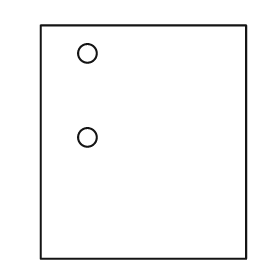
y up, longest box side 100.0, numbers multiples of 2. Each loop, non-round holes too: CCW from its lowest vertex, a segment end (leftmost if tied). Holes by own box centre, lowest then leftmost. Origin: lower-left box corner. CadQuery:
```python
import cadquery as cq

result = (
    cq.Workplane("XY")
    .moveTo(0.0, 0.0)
    .lineTo(88.0, 0.0)
    .lineTo(88.0, 100.0)
    .lineTo(0.0, 100.0)
    .close()
    .moveTo(20.0, 52.0)
    .circle(4.0)
    .moveTo(20.0, 88.0)
    .circle(4.0)
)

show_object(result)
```